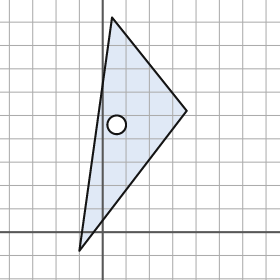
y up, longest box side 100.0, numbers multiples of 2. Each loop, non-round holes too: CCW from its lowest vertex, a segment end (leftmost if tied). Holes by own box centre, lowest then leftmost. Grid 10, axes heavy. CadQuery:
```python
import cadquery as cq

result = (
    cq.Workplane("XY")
    .moveTo(-10.0, -8.0)
    .lineTo(36.0, 52.0)
    .lineTo(4.0, 92.0)
    .close()
    .moveTo(6.0, 46.0)
    .circle(4.0)
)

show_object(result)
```